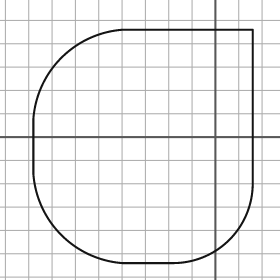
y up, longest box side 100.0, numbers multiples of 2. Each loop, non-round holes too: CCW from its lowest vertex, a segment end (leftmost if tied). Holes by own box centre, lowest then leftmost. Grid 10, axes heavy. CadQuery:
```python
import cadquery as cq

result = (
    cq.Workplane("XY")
    .moveTo(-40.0, -54.0)
    .lineTo(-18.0, -54.0)
    .threePointArc((6.0, -44.0), (16.0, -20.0))
    .lineTo(16.0, 46.0)
    .lineTo(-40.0, 46.0)
    .threePointArc((-66.0, 34.0), (-78.0, 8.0))
    .lineTo(-78.0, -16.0)
    .threePointArc((-66.0, -42.0), (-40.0, -54.0))
    .close()
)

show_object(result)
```